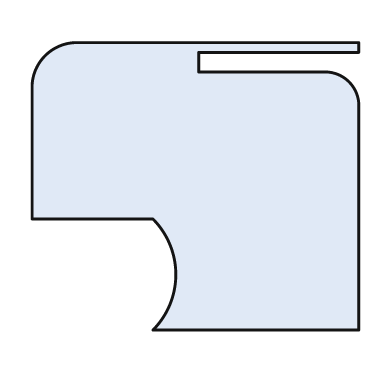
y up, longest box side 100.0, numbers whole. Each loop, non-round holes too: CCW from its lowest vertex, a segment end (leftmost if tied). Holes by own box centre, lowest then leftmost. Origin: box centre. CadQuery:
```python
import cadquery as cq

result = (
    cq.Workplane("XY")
    .moveTo(-13.0, -44.0)
    .lineTo(50.0, -44.0)
    .lineTo(50.0, 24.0)
    .threePointArc((47.0, 32.0), (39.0, 35.0))
    .lineTo(1.0, 35.0)
    .lineTo(1.0, 41.0)
    .lineTo(50.0, 41.0)
    .lineTo(50.0, 44.0)
    .lineTo(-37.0, 44.0)
    .threePointArc((-46.0, 40.0), (-50.0, 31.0))
    .lineTo(-50.0, -10.0)
    .lineTo(-13.0, -10.0)
    .threePointArc((-6.0, -27.0), (-13.0, -44.0))
    .close()
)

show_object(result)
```